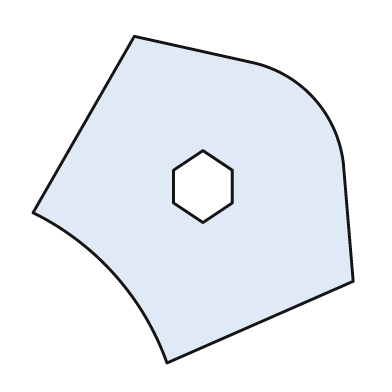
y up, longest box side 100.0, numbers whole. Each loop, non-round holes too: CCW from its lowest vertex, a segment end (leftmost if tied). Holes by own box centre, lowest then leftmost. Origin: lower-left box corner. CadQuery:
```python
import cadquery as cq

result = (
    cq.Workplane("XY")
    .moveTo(41.0, 0.0)
    .lineTo(98.0, 25.0)
    .lineTo(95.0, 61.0)
    .threePointArc((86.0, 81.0), (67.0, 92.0))
    .lineTo(31.0, 100.0)
    .lineTo(0.0, 46.0)
    .threePointArc((25.0, 27.0), (41.0, 0.0))
    .close()
    .moveTo(52.0, 43.0)
    .lineTo(61.0, 49.0)
    .lineTo(61.0, 59.0)
    .lineTo(52.0, 65.0)
    .lineTo(43.0, 59.0)
    .lineTo(43.0, 49.0)
    .close()
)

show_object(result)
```